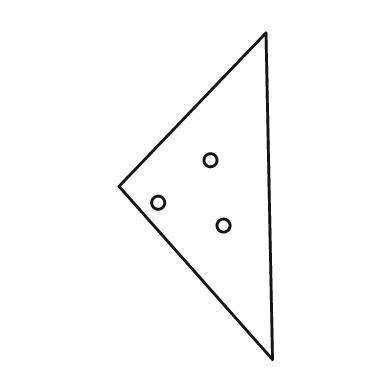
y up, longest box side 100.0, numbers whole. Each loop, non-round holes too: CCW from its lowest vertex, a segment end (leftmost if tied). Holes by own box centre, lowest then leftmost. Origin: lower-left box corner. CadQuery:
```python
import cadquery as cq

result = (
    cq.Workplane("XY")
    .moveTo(47.0, 0.0)
    .lineTo(45.0, 100.0)
    .lineTo(0.0, 53.0)
    .close()
    .moveTo(32.0, 41.0)
    .circle(2.0)
    .moveTo(12.0, 48.0)
    .circle(2.0)
    .moveTo(28.0, 61.0)
    .circle(2.0)
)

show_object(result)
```